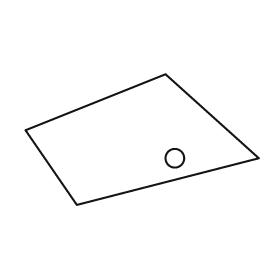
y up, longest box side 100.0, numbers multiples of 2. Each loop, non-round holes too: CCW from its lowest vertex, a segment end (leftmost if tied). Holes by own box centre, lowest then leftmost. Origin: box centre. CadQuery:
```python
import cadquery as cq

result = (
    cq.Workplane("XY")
    .moveTo(-28.0, -28.0)
    .lineTo(50.0, -8.0)
    .lineTo(10.0, 28.0)
    .lineTo(-50.0, 4.0)
    .close()
    .moveTo(14.0, -8.0)
    .circle(4.0)
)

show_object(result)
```